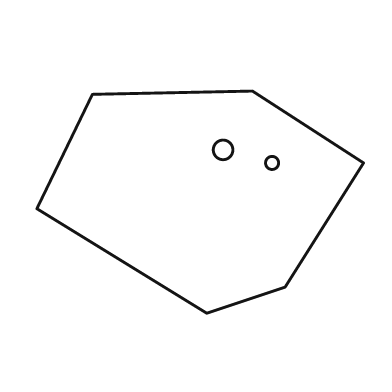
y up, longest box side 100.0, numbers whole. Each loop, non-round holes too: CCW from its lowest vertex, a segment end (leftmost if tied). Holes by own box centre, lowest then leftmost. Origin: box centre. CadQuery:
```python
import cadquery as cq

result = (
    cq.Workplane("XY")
    .moveTo(2.0, -34.0)
    .lineTo(26.0, -26.0)
    .lineTo(50.0, 12.0)
    .lineTo(16.0, 34.0)
    .lineTo(-33.0, 33.0)
    .lineTo(-50.0, -2.0)
    .close()
    .moveTo(22.0, 12.0)
    .circle(2.0)
    .moveTo(7.0, 16.0)
    .circle(3.0)
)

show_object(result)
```